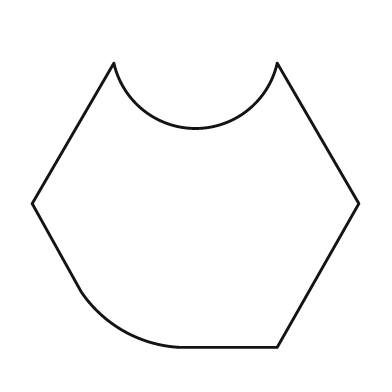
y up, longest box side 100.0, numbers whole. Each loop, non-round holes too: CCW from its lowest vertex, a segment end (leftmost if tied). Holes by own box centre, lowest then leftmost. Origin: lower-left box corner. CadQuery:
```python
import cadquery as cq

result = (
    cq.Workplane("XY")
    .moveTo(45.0, 0.0)
    .lineTo(75.0, 0.0)
    .lineTo(100.0, 44.0)
    .lineTo(75.0, 87.0)
    .threePointArc((50.0, 67.0), (25.0, 87.0))
    .lineTo(0.0, 44.0)
    .lineTo(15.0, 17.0)
    .threePointArc((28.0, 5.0), (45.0, 0.0))
    .close()
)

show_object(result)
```